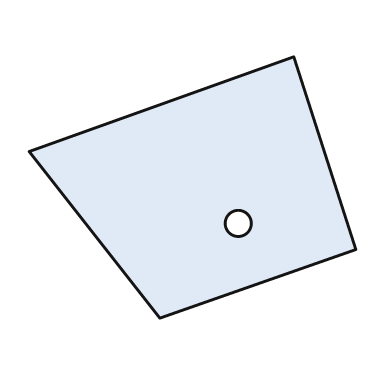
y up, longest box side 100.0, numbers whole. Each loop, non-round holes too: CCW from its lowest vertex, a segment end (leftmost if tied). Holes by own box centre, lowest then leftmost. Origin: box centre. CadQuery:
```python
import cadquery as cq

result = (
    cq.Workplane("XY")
    .moveTo(-10.0, -40.0)
    .lineTo(50.0, -19.0)
    .lineTo(31.0, 40.0)
    .lineTo(-50.0, 11.0)
    .close()
    .moveTo(14.0, -11.0)
    .circle(4.0)
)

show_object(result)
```